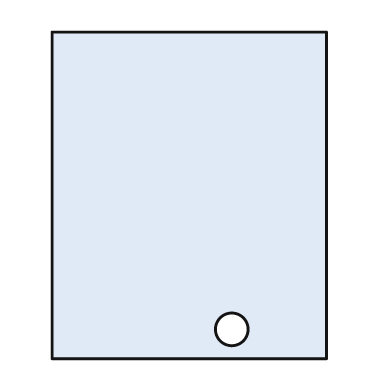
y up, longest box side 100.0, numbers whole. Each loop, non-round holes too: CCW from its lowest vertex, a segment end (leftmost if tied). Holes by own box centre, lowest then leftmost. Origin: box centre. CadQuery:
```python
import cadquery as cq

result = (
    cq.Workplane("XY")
    .moveTo(-42.0, -50.0)
    .lineTo(42.0, -50.0)
    .lineTo(42.0, 50.0)
    .lineTo(-42.0, 50.0)
    .close()
    .moveTo(13.0, -41.0)
    .circle(5.0)
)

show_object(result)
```